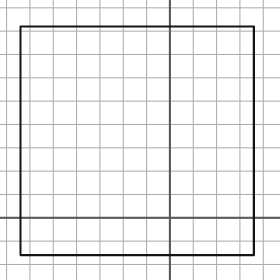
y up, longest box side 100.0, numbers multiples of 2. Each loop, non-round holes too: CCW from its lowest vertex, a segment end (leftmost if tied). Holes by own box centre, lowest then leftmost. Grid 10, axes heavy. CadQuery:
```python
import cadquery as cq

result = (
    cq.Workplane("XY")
    .moveTo(-64.0, -16.0)
    .lineTo(36.0, -16.0)
    .lineTo(36.0, 82.0)
    .lineTo(-64.0, 82.0)
    .close()
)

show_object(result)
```